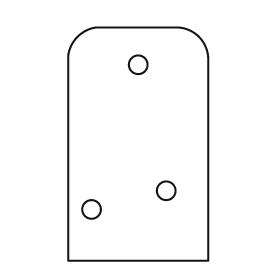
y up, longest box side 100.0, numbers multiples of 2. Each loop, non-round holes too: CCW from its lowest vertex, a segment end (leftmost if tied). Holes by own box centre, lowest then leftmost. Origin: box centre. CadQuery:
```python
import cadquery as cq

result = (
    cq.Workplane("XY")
    .moveTo(-30.0, -50.0)
    .lineTo(30.0, -50.0)
    .lineTo(30.0, 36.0)
    .threePointArc((26.0, 46.0), (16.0, 50.0))
    .lineTo(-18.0, 50.0)
    .threePointArc((-26.0, 46.0), (-30.0, 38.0))
    .close()
    .moveTo(-20.0, -28.0)
    .circle(4.0)
    .moveTo(12.0, -20.0)
    .circle(4.0)
    .moveTo(0.0, 34.0)
    .circle(4.0)
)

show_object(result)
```